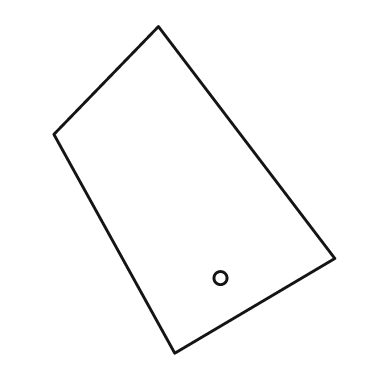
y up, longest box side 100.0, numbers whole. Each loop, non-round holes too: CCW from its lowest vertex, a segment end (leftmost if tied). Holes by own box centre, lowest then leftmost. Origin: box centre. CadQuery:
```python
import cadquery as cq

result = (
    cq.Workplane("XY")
    .moveTo(-6.0, -50.0)
    .lineTo(43.0, -21.0)
    .lineTo(-11.0, 50.0)
    .lineTo(-43.0, 17.0)
    .close()
    .moveTo(8.0, -27.0)
    .circle(2.0)
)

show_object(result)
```